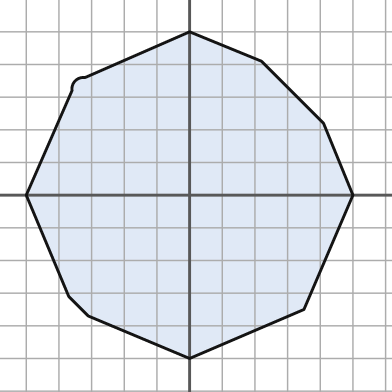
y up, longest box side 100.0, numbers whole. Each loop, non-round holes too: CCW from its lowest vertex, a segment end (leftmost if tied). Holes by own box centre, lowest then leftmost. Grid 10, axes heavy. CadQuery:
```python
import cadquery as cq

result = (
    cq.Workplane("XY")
    .moveTo(0.0, -50.0)
    .lineTo(35.0, -35.0)
    .lineTo(50.0, 0.0)
    .lineTo(41.0, 22.0)
    .lineTo(22.0, 41.0)
    .lineTo(0.0, 50.0)
    .lineTo(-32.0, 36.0)
    .threePointArc((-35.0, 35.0), (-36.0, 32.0))
    .lineTo(-50.0, 0.0)
    .lineTo(-37.0, -31.0)
    .lineTo(-31.0, -37.0)
    .close()
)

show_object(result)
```